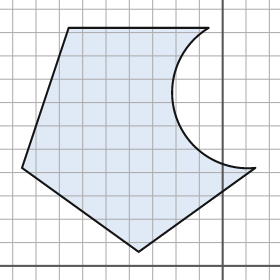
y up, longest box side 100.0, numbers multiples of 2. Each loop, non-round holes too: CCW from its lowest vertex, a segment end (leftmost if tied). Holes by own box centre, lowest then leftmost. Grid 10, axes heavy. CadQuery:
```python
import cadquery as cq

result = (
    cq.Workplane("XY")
    .moveTo(-36.0, 6.0)
    .lineTo(14.0, 42.0)
    .threePointArc((-20.0, 64.0), (-6.0, 102.0))
    .lineTo(-66.0, 102.0)
    .lineTo(-86.0, 42.0)
    .close()
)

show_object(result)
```